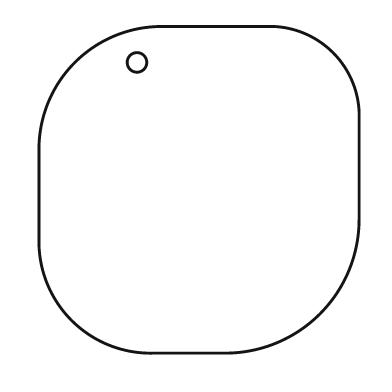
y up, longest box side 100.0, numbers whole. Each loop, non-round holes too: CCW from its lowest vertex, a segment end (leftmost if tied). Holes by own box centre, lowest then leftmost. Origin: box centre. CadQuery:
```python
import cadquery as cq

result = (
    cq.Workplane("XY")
    .moveTo(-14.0, -50.0)
    .lineTo(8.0, -50.0)
    .threePointArc((37.0, -38.0), (49.0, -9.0))
    .lineTo(49.0, 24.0)
    .threePointArc((41.0, 42.0), (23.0, 50.0))
    .lineTo(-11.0, 50.0)
    .threePointArc((-38.0, 39.0), (-49.0, 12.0))
    .lineTo(-49.0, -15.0)
    .threePointArc((-39.0, -40.0), (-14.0, -50.0))
    .close()
    .moveTo(-19.0, 39.0)
    .circle(3.0)
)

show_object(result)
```